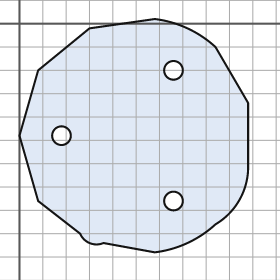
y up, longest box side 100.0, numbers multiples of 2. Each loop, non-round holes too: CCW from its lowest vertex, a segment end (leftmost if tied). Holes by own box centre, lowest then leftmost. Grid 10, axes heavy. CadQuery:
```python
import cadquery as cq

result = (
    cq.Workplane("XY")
    .moveTo(58.0, -98.0)
    .threePointArc((72.0, -94.0), (84.0, -86.0))
    .threePointArc((94.0, -76.0), (98.0, -62.0))
    .lineTo(98.0, -34.0)
    .lineTo(84.0, -10.0)
    .threePointArc((72.0, -2.0), (58.0, 2.0))
    .lineTo(30.0, -2.0)
    .lineTo(8.0, -20.0)
    .lineTo(0.0, -48.0)
    .lineTo(8.0, -76.0)
    .lineTo(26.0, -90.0)
    .threePointArc((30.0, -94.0), (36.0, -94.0))
    .close()
    .moveTo(66.0, -76.0)
    .circle(4.0)
    .moveTo(18.0, -48.0)
    .circle(4.0)
    .moveTo(66.0, -20.0)
    .circle(4.0)
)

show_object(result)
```